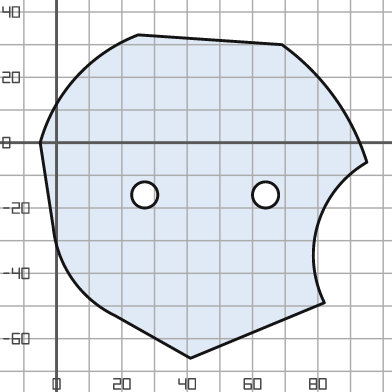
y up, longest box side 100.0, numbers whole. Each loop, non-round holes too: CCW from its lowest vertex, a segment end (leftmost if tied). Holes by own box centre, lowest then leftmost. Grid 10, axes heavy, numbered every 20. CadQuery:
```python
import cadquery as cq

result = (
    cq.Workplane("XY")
    .moveTo(41.0, -66.0)
    .lineTo(82.0, -49.0)
    .threePointArc((80.0, -25.0), (95.0, -6.0))
    .threePointArc((85.0, 14.0), (69.0, 30.0))
    .lineTo(25.0, 33.0)
    .threePointArc((6.0, 20.0), (-5.0, 0.0))
    .lineTo(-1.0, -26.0)
    .threePointArc((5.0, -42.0), (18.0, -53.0))
    .close()
    .moveTo(27.0, -16.0)
    .circle(4.0)
    .moveTo(64.0, -16.0)
    .circle(4.0)
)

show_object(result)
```